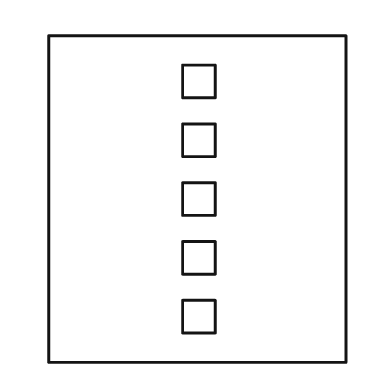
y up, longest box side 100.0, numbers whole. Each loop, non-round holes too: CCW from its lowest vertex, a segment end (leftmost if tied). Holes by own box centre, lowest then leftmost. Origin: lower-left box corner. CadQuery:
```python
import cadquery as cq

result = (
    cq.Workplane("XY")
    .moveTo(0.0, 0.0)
    .lineTo(91.0, 0.0)
    .lineTo(91.0, 100.0)
    .lineTo(0.0, 100.0)
    .close()
    .moveTo(41.0, 9.0)
    .lineTo(51.0, 9.0)
    .lineTo(51.0, 19.0)
    .lineTo(41.0, 19.0)
    .close()
    .moveTo(41.0, 27.0)
    .lineTo(51.0, 27.0)
    .lineTo(51.0, 37.0)
    .lineTo(41.0, 37.0)
    .close()
    .moveTo(41.0, 45.0)
    .lineTo(51.0, 45.0)
    .lineTo(51.0, 55.0)
    .lineTo(41.0, 55.0)
    .close()
    .moveTo(41.0, 63.0)
    .lineTo(51.0, 63.0)
    .lineTo(51.0, 73.0)
    .lineTo(41.0, 73.0)
    .close()
    .moveTo(41.0, 81.0)
    .lineTo(51.0, 81.0)
    .lineTo(51.0, 91.0)
    .lineTo(41.0, 91.0)
    .close()
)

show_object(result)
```